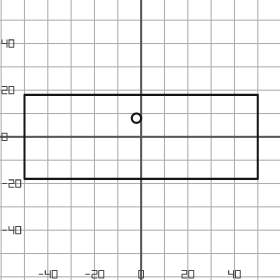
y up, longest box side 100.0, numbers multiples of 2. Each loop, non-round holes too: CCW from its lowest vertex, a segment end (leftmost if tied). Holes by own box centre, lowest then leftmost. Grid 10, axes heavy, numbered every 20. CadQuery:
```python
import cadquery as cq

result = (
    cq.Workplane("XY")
    .moveTo(-50.0, -18.0)
    .lineTo(50.0, -18.0)
    .lineTo(50.0, 18.0)
    .lineTo(-50.0, 18.0)
    .close()
    .moveTo(-2.0, 8.0)
    .circle(2.0)
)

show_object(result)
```